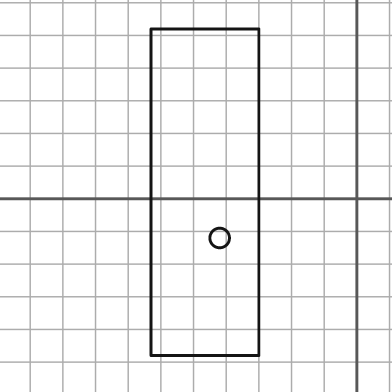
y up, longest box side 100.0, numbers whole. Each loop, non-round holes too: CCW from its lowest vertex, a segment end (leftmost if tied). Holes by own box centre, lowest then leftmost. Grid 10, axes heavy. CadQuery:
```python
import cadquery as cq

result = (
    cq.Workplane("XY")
    .moveTo(-63.0, -48.0)
    .lineTo(-30.0, -48.0)
    .lineTo(-30.0, 52.0)
    .lineTo(-63.0, 52.0)
    .close()
    .moveTo(-42.0, -12.0)
    .circle(3.0)
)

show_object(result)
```